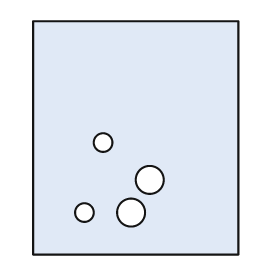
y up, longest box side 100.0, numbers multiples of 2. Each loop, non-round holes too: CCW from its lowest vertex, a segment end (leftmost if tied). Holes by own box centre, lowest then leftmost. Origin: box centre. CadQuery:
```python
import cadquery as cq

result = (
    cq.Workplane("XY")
    .moveTo(-44.0, -50.0)
    .lineTo(44.0, -50.0)
    .lineTo(44.0, 50.0)
    .lineTo(-44.0, 50.0)
    .close()
    .moveTo(-22.0, -32.0)
    .circle(4.0)
    .moveTo(-2.0, -32.0)
    .circle(6.0)
    .moveTo(6.0, -18.0)
    .circle(6.0)
    .moveTo(-14.0, -2.0)
    .circle(4.0)
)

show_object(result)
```